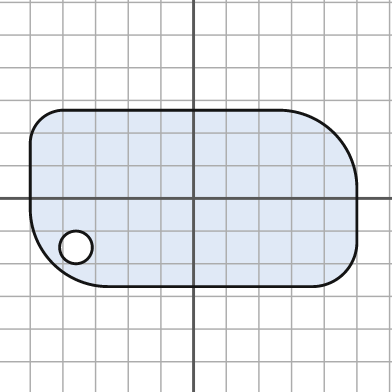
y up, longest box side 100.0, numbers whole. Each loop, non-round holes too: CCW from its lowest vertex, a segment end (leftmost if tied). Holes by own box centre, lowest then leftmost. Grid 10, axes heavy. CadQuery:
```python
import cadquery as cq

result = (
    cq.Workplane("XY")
    .moveTo(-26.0, -27.0)
    .lineTo(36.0, -27.0)
    .threePointArc((46.0, -23.0), (50.0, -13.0))
    .lineTo(50.0, 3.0)
    .threePointArc((43.0, 20.0), (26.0, 27.0))
    .lineTo(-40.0, 27.0)
    .threePointArc((-47.0, 24.0), (-50.0, 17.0))
    .lineTo(-50.0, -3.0)
    .threePointArc((-43.0, -20.0), (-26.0, -27.0))
    .close()
    .moveTo(-36.0, -15.0)
    .circle(5.0)
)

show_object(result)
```